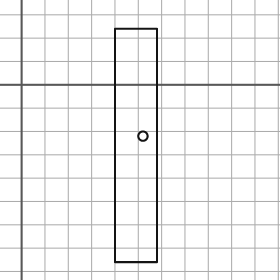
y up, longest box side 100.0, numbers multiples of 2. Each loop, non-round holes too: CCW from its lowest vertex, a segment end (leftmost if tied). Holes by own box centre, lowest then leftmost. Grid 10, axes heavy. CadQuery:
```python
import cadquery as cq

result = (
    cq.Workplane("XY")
    .moveTo(40.0, -76.0)
    .lineTo(58.0, -76.0)
    .lineTo(58.0, 24.0)
    .lineTo(40.0, 24.0)
    .close()
    .moveTo(52.0, -22.0)
    .circle(2.0)
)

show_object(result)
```